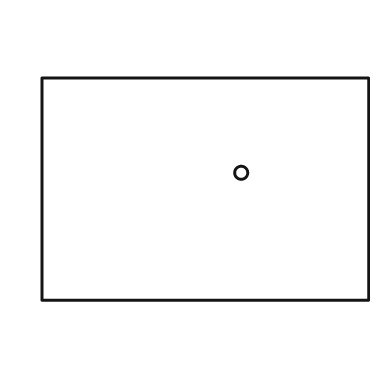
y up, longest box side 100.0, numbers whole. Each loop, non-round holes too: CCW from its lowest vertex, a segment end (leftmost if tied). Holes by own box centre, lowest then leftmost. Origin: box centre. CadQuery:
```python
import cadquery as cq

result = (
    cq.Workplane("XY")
    .moveTo(-50.0, -34.0)
    .lineTo(50.0, -34.0)
    .lineTo(50.0, 34.0)
    .lineTo(-50.0, 34.0)
    .close()
    .moveTo(11.0, 5.0)
    .circle(2.0)
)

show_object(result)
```